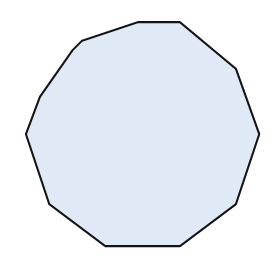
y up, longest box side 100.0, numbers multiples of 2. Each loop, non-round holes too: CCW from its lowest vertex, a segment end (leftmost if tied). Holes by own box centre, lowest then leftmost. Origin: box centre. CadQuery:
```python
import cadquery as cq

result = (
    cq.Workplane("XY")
    .moveTo(-16.0, -48.0)
    .lineTo(16.0, -48.0)
    .lineTo(40.0, -30.0)
    .lineTo(50.0, 0.0)
    .lineTo(40.0, 28.0)
    .lineTo(16.0, 48.0)
    .lineTo(-2.0, 48.0)
    .lineTo(-26.0, 40.0)
    .lineTo(-30.0, 36.0)
    .lineTo(-44.0, 16.0)
    .lineTo(-50.0, 0.0)
    .lineTo(-40.0, -30.0)
    .close()
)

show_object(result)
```